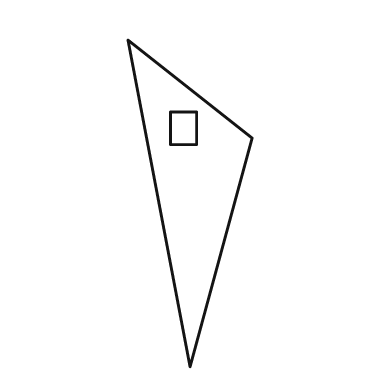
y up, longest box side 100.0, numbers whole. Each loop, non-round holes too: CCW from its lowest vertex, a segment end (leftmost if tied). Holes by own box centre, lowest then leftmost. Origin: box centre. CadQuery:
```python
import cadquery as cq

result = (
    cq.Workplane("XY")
    .moveTo(0.0, -50.0)
    .lineTo(19.0, 20.0)
    .lineTo(-19.0, 50.0)
    .close()
    .moveTo(-6.0, 18.0)
    .lineTo(2.0, 18.0)
    .lineTo(2.0, 28.0)
    .lineTo(-6.0, 28.0)
    .close()
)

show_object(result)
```